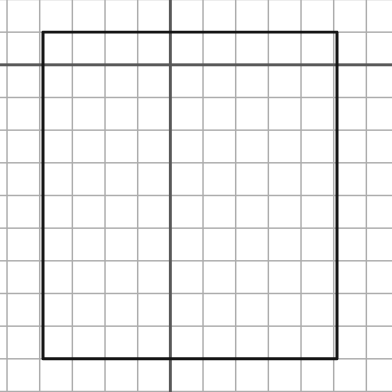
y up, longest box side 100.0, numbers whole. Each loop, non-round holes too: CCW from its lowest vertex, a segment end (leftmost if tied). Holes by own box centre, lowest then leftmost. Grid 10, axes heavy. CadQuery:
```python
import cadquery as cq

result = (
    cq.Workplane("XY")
    .moveTo(-39.0, -90.0)
    .lineTo(51.0, -90.0)
    .lineTo(51.0, 10.0)
    .lineTo(-39.0, 10.0)
    .close()
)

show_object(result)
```